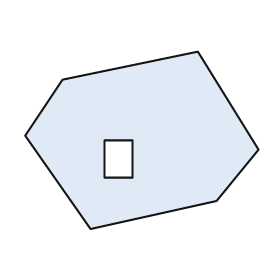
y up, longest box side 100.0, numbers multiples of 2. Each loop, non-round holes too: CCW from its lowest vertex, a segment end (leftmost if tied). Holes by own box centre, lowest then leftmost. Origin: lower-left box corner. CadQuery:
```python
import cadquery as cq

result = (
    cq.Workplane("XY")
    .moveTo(28.0, 0.0)
    .lineTo(82.0, 12.0)
    .lineTo(100.0, 34.0)
    .lineTo(74.0, 76.0)
    .lineTo(16.0, 64.0)
    .lineTo(0.0, 40.0)
    .close()
    .moveTo(34.0, 22.0)
    .lineTo(46.0, 22.0)
    .lineTo(46.0, 38.0)
    .lineTo(34.0, 38.0)
    .close()
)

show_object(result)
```